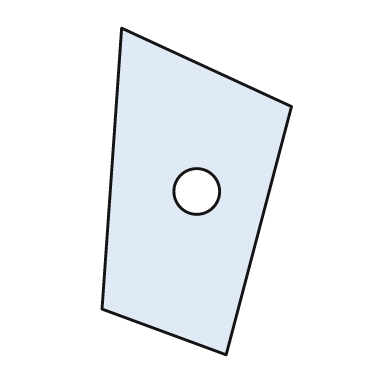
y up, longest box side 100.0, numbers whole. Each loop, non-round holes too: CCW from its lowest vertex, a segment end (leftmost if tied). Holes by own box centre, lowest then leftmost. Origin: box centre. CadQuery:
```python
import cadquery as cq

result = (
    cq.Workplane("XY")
    .moveTo(9.0, -50.0)
    .lineTo(29.0, 26.0)
    .lineTo(-23.0, 50.0)
    .lineTo(-29.0, -36.0)
    .close()
    .moveTo(0.0, 0.0)
    .circle(7.0)
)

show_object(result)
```